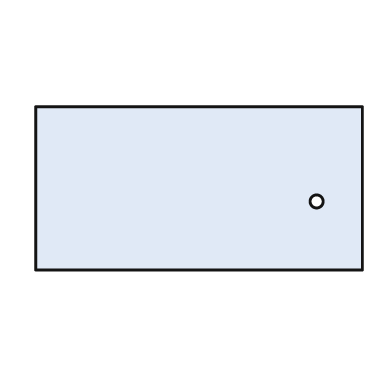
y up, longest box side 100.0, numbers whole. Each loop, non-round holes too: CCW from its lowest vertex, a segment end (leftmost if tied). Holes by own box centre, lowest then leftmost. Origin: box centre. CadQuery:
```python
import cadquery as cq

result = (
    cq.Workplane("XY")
    .moveTo(-50.0, -25.0)
    .lineTo(50.0, -25.0)
    .lineTo(50.0, 25.0)
    .lineTo(-50.0, 25.0)
    .close()
    .moveTo(36.0, -4.0)
    .circle(2.0)
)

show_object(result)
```